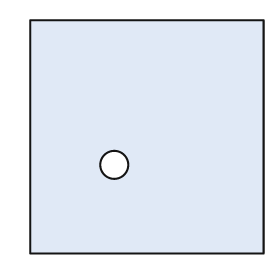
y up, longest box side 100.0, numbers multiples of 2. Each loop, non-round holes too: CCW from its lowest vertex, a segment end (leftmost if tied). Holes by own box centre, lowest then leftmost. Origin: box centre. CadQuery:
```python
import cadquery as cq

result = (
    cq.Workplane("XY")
    .moveTo(-50.0, -50.0)
    .lineTo(50.0, -50.0)
    .lineTo(50.0, 50.0)
    .lineTo(-50.0, 50.0)
    .close()
    .moveTo(-14.0, -12.0)
    .circle(6.0)
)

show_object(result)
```